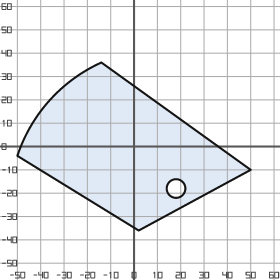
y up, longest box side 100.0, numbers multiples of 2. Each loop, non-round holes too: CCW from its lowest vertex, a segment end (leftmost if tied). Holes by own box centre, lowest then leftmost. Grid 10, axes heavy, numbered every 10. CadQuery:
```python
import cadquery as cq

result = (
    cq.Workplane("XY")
    .moveTo(2.0, -36.0)
    .lineTo(50.0, -10.0)
    .lineTo(-14.0, 36.0)
    .threePointArc((-36.0, 20.0), (-50.0, -4.0))
    .close()
    .moveTo(18.0, -18.0)
    .circle(4.0)
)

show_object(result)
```